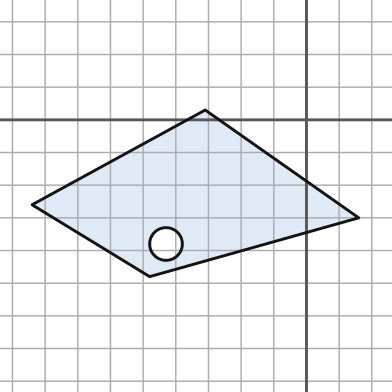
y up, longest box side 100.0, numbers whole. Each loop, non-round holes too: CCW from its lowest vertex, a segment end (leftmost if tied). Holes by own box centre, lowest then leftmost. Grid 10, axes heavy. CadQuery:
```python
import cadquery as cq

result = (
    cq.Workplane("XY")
    .moveTo(-48.0, -48.0)
    .lineTo(16.0, -30.0)
    .lineTo(-31.0, 3.0)
    .lineTo(-84.0, -26.0)
    .close()
    .moveTo(-43.0, -38.0)
    .circle(5.0)
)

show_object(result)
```